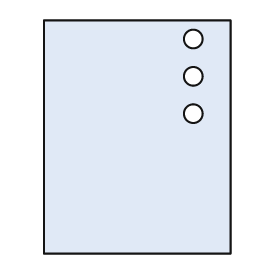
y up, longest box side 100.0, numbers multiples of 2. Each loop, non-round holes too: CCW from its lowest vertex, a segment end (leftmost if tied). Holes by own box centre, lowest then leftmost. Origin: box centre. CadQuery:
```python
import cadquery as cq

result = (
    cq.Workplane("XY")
    .moveTo(-40.0, -50.0)
    .lineTo(40.0, -50.0)
    .lineTo(40.0, 50.0)
    .lineTo(-40.0, 50.0)
    .close()
    .moveTo(24.0, 10.0)
    .circle(4.0)
    .moveTo(24.0, 26.0)
    .circle(4.0)
    .moveTo(24.0, 42.0)
    .circle(4.0)
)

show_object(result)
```